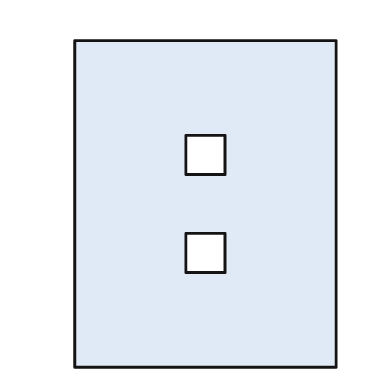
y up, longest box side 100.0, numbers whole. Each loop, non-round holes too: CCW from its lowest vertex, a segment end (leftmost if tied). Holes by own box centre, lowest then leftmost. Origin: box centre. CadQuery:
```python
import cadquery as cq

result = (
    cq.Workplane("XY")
    .moveTo(-40.0, -50.0)
    .lineTo(40.0, -50.0)
    .lineTo(40.0, 50.0)
    .lineTo(-40.0, 50.0)
    .close()
    .moveTo(-6.0, -21.0)
    .lineTo(6.0, -21.0)
    .lineTo(6.0, -9.0)
    .lineTo(-6.0, -9.0)
    .close()
    .moveTo(-6.0, 9.0)
    .lineTo(6.0, 9.0)
    .lineTo(6.0, 21.0)
    .lineTo(-6.0, 21.0)
    .close()
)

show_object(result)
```